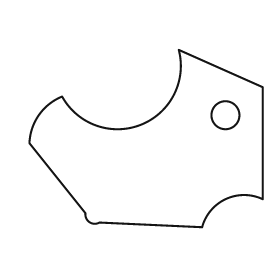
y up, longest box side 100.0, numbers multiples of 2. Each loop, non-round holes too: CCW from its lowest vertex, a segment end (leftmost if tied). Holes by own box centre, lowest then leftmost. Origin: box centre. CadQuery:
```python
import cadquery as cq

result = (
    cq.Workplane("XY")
    .moveTo(24.0, -38.0)
    .threePointArc((34.0, -26.0), (50.0, -26.0))
    .lineTo(50.0, 22.0)
    .lineTo(14.0, 38.0)
    .threePointArc((-2.0, 6.0), (-36.0, 18.0))
    .threePointArc((-46.0, 10.0), (-50.0, -2.0))
    .lineTo(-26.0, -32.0)
    .threePointArc((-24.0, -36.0), (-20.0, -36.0))
    .close()
    .moveTo(34.0, 10.0)
    .circle(6.0)
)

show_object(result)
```